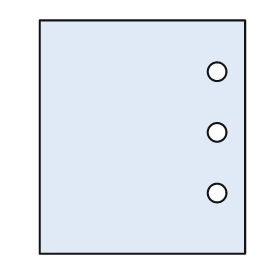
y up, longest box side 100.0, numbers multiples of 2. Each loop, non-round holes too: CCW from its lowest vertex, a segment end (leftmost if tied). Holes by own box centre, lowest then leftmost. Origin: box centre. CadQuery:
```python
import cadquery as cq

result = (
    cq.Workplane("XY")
    .moveTo(-44.0, -50.0)
    .lineTo(44.0, -50.0)
    .lineTo(44.0, 50.0)
    .lineTo(-44.0, 50.0)
    .close()
    .moveTo(32.0, -24.0)
    .circle(4.0)
    .moveTo(32.0, 2.0)
    .circle(4.0)
    .moveTo(32.0, 28.0)
    .circle(4.0)
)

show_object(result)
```